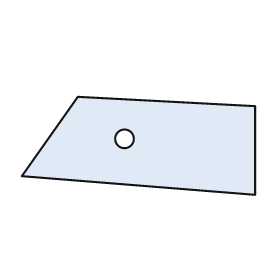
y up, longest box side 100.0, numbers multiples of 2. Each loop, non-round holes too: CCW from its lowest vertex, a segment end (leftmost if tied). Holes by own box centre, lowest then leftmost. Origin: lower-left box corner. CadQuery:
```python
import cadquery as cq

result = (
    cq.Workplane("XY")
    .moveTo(100.0, 0.0)
    .lineTo(100.0, 38.0)
    .lineTo(24.0, 42.0)
    .lineTo(0.0, 8.0)
    .close()
    .moveTo(44.0, 24.0)
    .circle(4.0)
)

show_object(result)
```